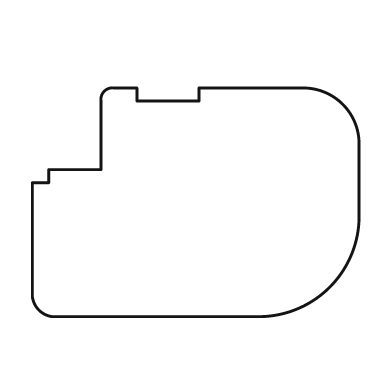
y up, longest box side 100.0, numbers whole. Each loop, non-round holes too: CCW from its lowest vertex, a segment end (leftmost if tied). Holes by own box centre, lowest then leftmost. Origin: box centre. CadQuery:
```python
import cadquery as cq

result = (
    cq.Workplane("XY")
    .moveTo(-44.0, -35.0)
    .lineTo(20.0, -35.0)
    .threePointArc((41.0, -26.0), (50.0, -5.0))
    .lineTo(50.0, 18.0)
    .threePointArc((45.0, 30.0), (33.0, 35.0))
    .lineTo(1.0, 35.0)
    .lineTo(1.0, 31.0)
    .lineTo(-18.0, 31.0)
    .lineTo(-18.0, 35.0)
    .lineTo(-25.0, 35.0)
    .threePointArc((-28.0, 34.0), (-29.0, 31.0))
    .lineTo(-29.0, 10.0)
    .lineTo(-45.0, 10.0)
    .lineTo(-45.0, 6.0)
    .lineTo(-50.0, 6.0)
    .lineTo(-50.0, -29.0)
    .threePointArc((-48.0, -33.0), (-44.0, -35.0))
    .close()
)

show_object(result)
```